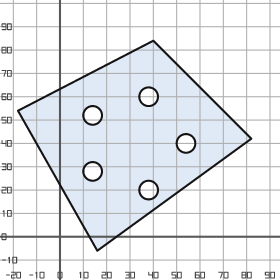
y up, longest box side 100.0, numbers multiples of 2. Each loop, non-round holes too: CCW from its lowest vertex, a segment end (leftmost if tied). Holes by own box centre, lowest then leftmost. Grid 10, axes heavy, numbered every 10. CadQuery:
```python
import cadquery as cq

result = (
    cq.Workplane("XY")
    .moveTo(16.0, -6.0)
    .lineTo(82.0, 42.0)
    .lineTo(40.0, 84.0)
    .lineTo(-18.0, 54.0)
    .close()
    .moveTo(38.0, 20.0)
    .circle(4.0)
    .moveTo(14.0, 28.0)
    .circle(4.0)
    .moveTo(54.0, 40.0)
    .circle(4.0)
    .moveTo(14.0, 52.0)
    .circle(4.0)
    .moveTo(38.0, 60.0)
    .circle(4.0)
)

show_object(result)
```